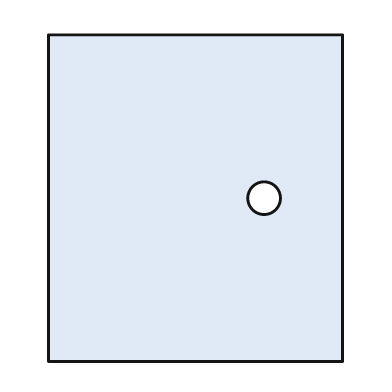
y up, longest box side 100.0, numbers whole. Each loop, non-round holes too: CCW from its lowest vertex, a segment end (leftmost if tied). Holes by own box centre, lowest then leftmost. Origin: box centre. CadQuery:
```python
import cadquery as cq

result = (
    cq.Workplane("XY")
    .moveTo(-45.0, -50.0)
    .lineTo(45.0, -50.0)
    .lineTo(45.0, 50.0)
    .lineTo(-45.0, 50.0)
    .close()
    .moveTo(21.0, 0.0)
    .circle(5.0)
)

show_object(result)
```